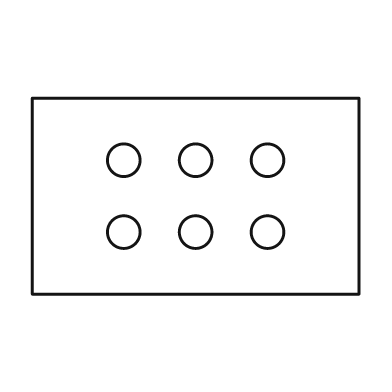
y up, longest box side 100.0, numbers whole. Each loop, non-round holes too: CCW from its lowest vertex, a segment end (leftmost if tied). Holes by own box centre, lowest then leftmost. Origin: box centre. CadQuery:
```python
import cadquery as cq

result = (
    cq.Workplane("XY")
    .moveTo(-50.0, -30.0)
    .lineTo(50.0, -30.0)
    .lineTo(50.0, 30.0)
    .lineTo(-50.0, 30.0)
    .close()
    .moveTo(-22.0, -11.0)
    .circle(5.0)
    .moveTo(0.0, -11.0)
    .circle(5.0)
    .moveTo(22.0, -11.0)
    .circle(5.0)
    .moveTo(-22.0, 11.0)
    .circle(5.0)
    .moveTo(0.0, 11.0)
    .circle(5.0)
    .moveTo(22.0, 11.0)
    .circle(5.0)
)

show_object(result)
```